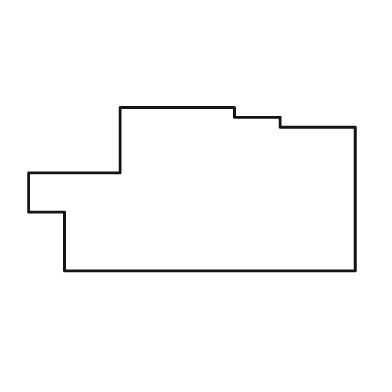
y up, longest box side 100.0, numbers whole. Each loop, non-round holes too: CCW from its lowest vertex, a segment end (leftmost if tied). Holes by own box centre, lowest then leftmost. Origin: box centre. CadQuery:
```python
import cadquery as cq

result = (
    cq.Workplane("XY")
    .moveTo(-39.0, -25.0)
    .lineTo(50.0, -25.0)
    .lineTo(50.0, 19.0)
    .lineTo(27.0, 19.0)
    .lineTo(27.0, 22.0)
    .lineTo(13.0, 22.0)
    .lineTo(13.0, 25.0)
    .lineTo(-22.0, 25.0)
    .lineTo(-22.0, 5.0)
    .lineTo(-50.0, 5.0)
    .lineTo(-50.0, -7.0)
    .lineTo(-39.0, -7.0)
    .close()
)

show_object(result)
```